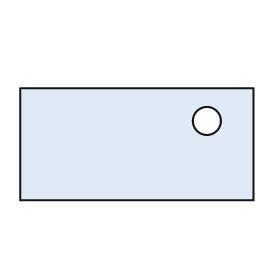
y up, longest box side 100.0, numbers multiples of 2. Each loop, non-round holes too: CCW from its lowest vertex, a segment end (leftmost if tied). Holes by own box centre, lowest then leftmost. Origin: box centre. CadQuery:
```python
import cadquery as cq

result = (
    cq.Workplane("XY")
    .moveTo(-50.0, -24.0)
    .lineTo(50.0, -24.0)
    .lineTo(50.0, 24.0)
    .lineTo(-50.0, 24.0)
    .close()
    .moveTo(30.0, 10.0)
    .circle(6.0)
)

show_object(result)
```